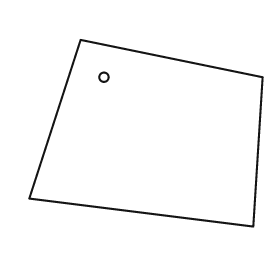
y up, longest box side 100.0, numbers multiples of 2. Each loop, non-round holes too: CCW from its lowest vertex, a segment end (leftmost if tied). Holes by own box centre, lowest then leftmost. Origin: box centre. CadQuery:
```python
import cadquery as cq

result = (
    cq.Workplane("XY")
    .moveTo(46.0, -40.0)
    .lineTo(50.0, 24.0)
    .lineTo(-28.0, 40.0)
    .lineTo(-50.0, -28.0)
    .close()
    .moveTo(-18.0, 24.0)
    .circle(2.0)
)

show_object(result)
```